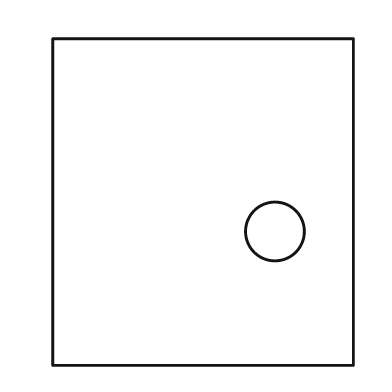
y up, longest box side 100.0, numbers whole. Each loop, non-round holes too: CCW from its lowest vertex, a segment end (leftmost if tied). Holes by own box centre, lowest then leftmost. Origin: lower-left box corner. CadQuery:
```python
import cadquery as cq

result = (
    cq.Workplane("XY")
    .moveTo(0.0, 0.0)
    .lineTo(92.0, 0.0)
    .lineTo(92.0, 100.0)
    .lineTo(0.0, 100.0)
    .close()
    .moveTo(68.0, 41.0)
    .circle(9.0)
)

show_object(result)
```